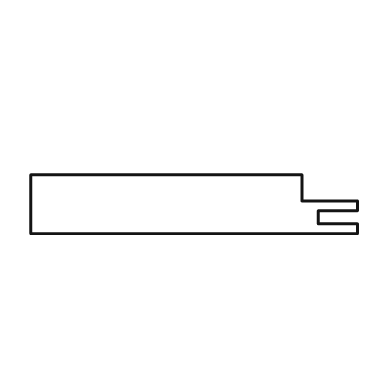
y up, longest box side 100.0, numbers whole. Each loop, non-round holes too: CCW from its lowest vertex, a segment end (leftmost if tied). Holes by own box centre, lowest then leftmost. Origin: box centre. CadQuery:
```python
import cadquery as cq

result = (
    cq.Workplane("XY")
    .moveTo(-50.0, -9.0)
    .lineTo(50.0, -9.0)
    .lineTo(50.0, -6.0)
    .lineTo(38.0, -6.0)
    .lineTo(38.0, -2.0)
    .lineTo(50.0, -2.0)
    .lineTo(50.0, 1.0)
    .lineTo(33.0, 1.0)
    .lineTo(33.0, 9.0)
    .lineTo(-50.0, 9.0)
    .close()
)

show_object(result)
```